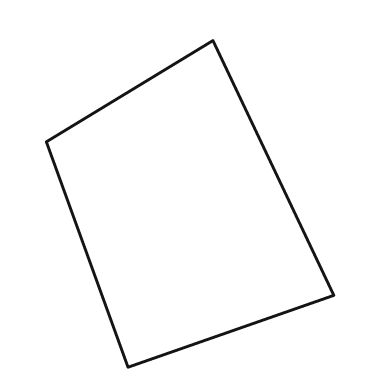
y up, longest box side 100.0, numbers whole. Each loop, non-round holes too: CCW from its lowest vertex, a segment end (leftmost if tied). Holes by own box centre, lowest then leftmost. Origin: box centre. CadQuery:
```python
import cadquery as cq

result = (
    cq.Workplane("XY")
    .moveTo(-19.0, -50.0)
    .lineTo(44.0, -28.0)
    .lineTo(7.0, 50.0)
    .lineTo(-44.0, 19.0)
    .close()
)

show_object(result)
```